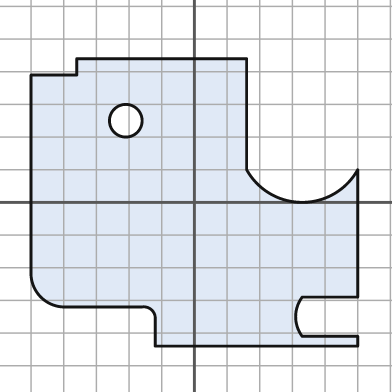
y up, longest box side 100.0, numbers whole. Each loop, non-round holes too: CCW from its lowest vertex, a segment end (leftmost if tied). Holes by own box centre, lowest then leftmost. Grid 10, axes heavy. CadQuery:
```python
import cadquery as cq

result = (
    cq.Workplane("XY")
    .moveTo(-12.0, -44.0)
    .lineTo(50.0, -44.0)
    .lineTo(50.0, -41.0)
    .lineTo(33.0, -41.0)
    .threePointArc((31.0, -35.0), (33.0, -29.0))
    .lineTo(50.0, -29.0)
    .lineTo(50.0, 10.0)
    .threePointArc((33.0, 0.0), (16.0, 10.0))
    .lineTo(16.0, 44.0)
    .lineTo(-36.0, 44.0)
    .lineTo(-36.0, 39.0)
    .lineTo(-50.0, 39.0)
    .lineTo(-50.0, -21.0)
    .threePointArc((-47.0, -29.0), (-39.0, -32.0))
    .lineTo(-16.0, -32.0)
    .threePointArc((-13.0, -33.0), (-12.0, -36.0))
    .close()
    .moveTo(-21.0, 25.0)
    .circle(5.0)
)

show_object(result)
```